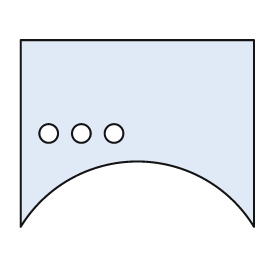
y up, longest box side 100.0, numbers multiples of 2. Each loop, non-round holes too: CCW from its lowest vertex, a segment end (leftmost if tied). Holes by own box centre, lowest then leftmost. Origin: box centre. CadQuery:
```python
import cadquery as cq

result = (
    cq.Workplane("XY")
    .moveTo(-50.0, -40.0)
    .threePointArc((0.0, -12.0), (50.0, -40.0))
    .lineTo(50.0, 40.0)
    .lineTo(-50.0, 40.0)
    .close()
    .moveTo(-38.0, 0.0)
    .circle(4.0)
    .moveTo(-24.0, 0.0)
    .circle(4.0)
    .moveTo(-10.0, 0.0)
    .circle(4.0)
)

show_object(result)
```